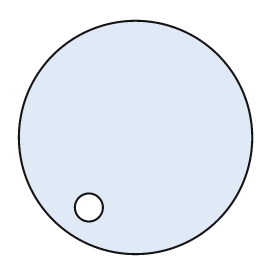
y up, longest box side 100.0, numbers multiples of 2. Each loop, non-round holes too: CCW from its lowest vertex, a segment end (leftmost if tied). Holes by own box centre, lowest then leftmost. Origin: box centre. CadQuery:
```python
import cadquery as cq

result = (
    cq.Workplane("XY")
    .moveTo(0.0, 0.0)
    .circle(50.0)
    .moveTo(-20.0, -30.0)
    .circle(6.0)
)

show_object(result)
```